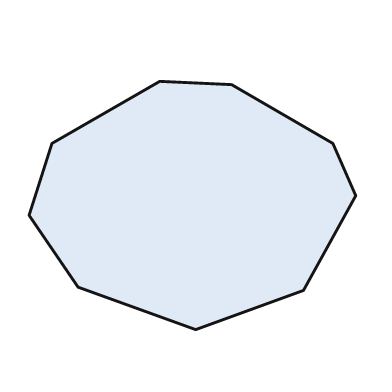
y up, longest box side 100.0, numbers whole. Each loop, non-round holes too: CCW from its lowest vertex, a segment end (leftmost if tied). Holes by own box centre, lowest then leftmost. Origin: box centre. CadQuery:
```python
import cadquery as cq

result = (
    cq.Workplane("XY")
    .moveTo(1.0, -38.0)
    .lineTo(34.0, -26.0)
    .lineTo(50.0, 3.0)
    .lineTo(43.0, 19.0)
    .lineTo(12.0, 37.0)
    .lineTo(-10.0, 38.0)
    .lineTo(-43.0, 19.0)
    .lineTo(-50.0, -3.0)
    .lineTo(-35.0, -25.0)
    .close()
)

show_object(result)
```